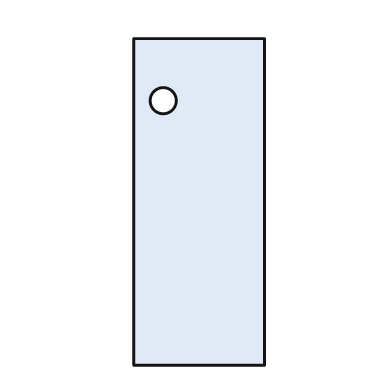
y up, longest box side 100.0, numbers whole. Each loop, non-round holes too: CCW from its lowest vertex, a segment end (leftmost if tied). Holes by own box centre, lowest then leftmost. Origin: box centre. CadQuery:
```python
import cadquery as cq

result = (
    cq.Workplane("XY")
    .moveTo(-20.0, -50.0)
    .lineTo(20.0, -50.0)
    .lineTo(20.0, 50.0)
    .lineTo(-20.0, 50.0)
    .close()
    .moveTo(-11.0, 31.0)
    .circle(4.0)
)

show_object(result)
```